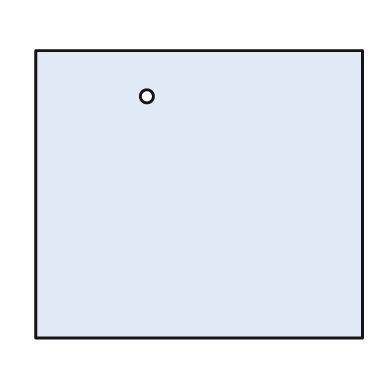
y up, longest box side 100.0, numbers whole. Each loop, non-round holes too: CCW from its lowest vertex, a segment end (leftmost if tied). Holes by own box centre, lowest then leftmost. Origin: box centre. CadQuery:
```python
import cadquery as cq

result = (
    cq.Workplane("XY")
    .moveTo(-50.0, -44.0)
    .lineTo(50.0, -44.0)
    .lineTo(50.0, 44.0)
    .lineTo(-50.0, 44.0)
    .close()
    .moveTo(-16.0, 30.0)
    .circle(2.0)
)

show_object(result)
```